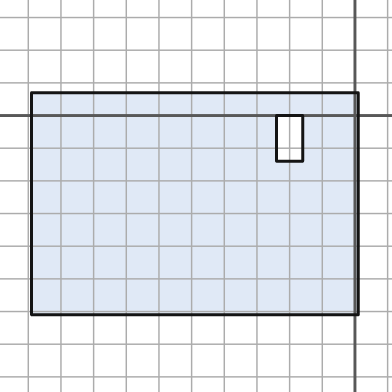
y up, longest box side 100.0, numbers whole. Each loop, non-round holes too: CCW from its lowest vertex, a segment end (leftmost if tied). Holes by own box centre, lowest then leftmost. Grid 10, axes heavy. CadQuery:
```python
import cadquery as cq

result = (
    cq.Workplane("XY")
    .moveTo(-99.0, -61.0)
    .lineTo(1.0, -61.0)
    .lineTo(1.0, 7.0)
    .lineTo(-99.0, 7.0)
    .close()
    .moveTo(-24.0, -14.0)
    .lineTo(-16.0, -14.0)
    .lineTo(-16.0, 0.0)
    .lineTo(-24.0, 0.0)
    .close()
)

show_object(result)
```